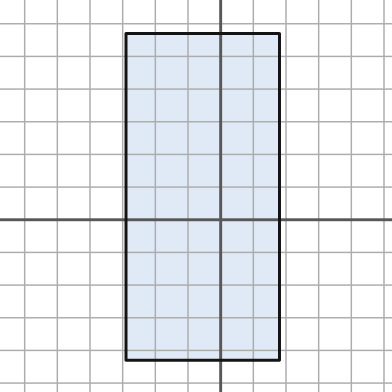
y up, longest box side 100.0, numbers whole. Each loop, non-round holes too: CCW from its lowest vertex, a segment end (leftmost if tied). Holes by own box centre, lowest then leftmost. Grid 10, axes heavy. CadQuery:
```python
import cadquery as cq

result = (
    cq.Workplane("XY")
    .moveTo(-29.0, -43.0)
    .lineTo(18.0, -43.0)
    .lineTo(18.0, 57.0)
    .lineTo(-29.0, 57.0)
    .close()
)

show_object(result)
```